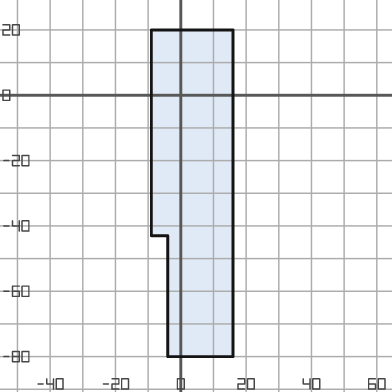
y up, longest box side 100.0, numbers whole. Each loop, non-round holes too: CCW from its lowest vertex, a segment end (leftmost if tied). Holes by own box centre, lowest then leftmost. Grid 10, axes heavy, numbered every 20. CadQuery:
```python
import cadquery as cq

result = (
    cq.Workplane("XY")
    .moveTo(-4.0, -80.0)
    .lineTo(16.0, -80.0)
    .lineTo(16.0, 20.0)
    .lineTo(-9.0, 20.0)
    .lineTo(-9.0, -43.0)
    .lineTo(-4.0, -43.0)
    .close()
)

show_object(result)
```